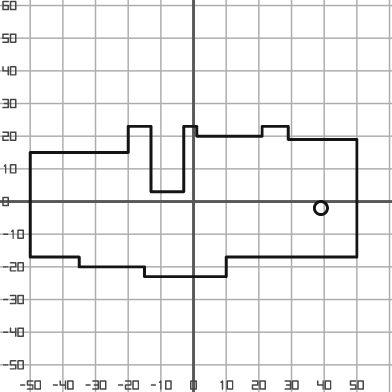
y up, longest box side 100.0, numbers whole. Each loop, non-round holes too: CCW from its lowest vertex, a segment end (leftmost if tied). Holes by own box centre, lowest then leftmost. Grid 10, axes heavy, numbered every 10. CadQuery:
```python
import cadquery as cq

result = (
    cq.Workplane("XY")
    .moveTo(-15.0, -23.0)
    .lineTo(10.0, -23.0)
    .lineTo(10.0, -17.0)
    .lineTo(50.0, -17.0)
    .lineTo(50.0, 19.0)
    .lineTo(29.0, 19.0)
    .lineTo(29.0, 23.0)
    .lineTo(21.0, 23.0)
    .lineTo(21.0, 20.0)
    .lineTo(1.0, 20.0)
    .lineTo(1.0, 23.0)
    .lineTo(-3.0, 23.0)
    .lineTo(-3.0, 3.0)
    .lineTo(-13.0, 3.0)
    .lineTo(-13.0, 23.0)
    .lineTo(-20.0, 23.0)
    .lineTo(-20.0, 15.0)
    .lineTo(-50.0, 15.0)
    .lineTo(-50.0, -17.0)
    .lineTo(-35.0, -17.0)
    .lineTo(-35.0, -20.0)
    .lineTo(-15.0, -20.0)
    .close()
    .moveTo(39.0, -2.0)
    .circle(2.0)
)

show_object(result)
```